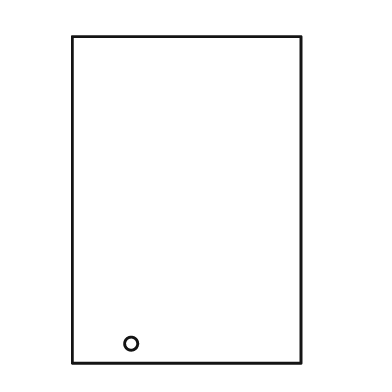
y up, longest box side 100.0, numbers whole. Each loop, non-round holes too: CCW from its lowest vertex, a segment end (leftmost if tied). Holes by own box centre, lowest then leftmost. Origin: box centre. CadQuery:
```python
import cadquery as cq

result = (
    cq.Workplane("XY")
    .moveTo(-35.0, -50.0)
    .lineTo(35.0, -50.0)
    .lineTo(35.0, 50.0)
    .lineTo(-35.0, 50.0)
    .close()
    .moveTo(-17.0, -44.0)
    .circle(2.0)
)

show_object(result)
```